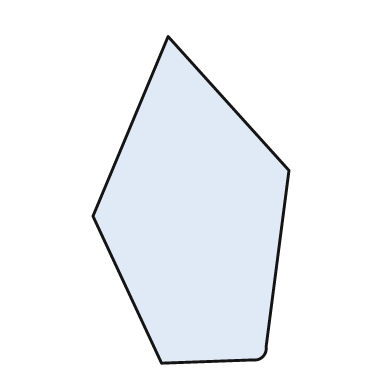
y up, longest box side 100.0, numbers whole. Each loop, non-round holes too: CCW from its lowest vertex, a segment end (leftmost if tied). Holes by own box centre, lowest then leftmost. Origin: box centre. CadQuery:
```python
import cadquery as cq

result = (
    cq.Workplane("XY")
    .moveTo(-9.0, -50.0)
    .lineTo(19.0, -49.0)
    .threePointArc((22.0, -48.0), (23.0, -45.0))
    .lineTo(30.0, 9.0)
    .lineTo(-7.0, 50.0)
    .lineTo(-30.0, -5.0)
    .close()
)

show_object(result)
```